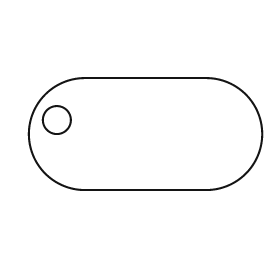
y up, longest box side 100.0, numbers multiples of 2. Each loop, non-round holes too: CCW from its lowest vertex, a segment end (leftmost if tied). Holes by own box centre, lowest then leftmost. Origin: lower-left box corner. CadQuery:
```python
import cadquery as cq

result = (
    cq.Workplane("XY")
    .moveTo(24.0, 0.0)
    .lineTo(76.0, 0.0)
    .threePointArc((100.0, 24.0), (76.0, 48.0))
    .lineTo(24.0, 48.0)
    .threePointArc((0.0, 24.0), (24.0, 0.0))
    .close()
    .moveTo(12.0, 30.0)
    .circle(6.0)
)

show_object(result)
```